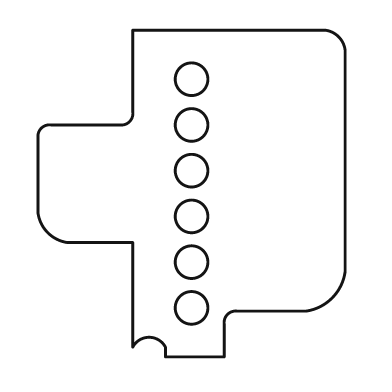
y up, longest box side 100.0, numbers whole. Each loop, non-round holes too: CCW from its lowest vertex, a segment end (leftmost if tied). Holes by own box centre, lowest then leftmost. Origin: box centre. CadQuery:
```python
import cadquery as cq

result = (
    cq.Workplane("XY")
    .moveTo(-8.0, -50.0)
    .lineTo(10.0, -50.0)
    .lineTo(10.0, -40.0)
    .threePointArc((11.0, -37.0), (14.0, -36.0))
    .lineTo(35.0, -36.0)
    .threePointArc((43.0, -32.0), (47.0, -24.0))
    .lineTo(47.0, 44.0)
    .threePointArc((45.0, 48.0), (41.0, 50.0))
    .lineTo(-18.0, 50.0)
    .lineTo(-18.0, 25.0)
    .threePointArc((-19.0, 22.0), (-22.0, 21.0))
    .lineTo(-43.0, 21.0)
    .threePointArc((-46.0, 20.0), (-47.0, 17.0))
    .lineTo(-47.0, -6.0)
    .threePointArc((-44.0, -12.0), (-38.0, -15.0))
    .lineTo(-18.0, -15.0)
    .lineTo(-18.0, -47.0)
    .threePointArc((-13.0, -44.0), (-8.0, -47.0))
    .close()
    .moveTo(0.0, -35.0)
    .circle(5.0)
    .moveTo(0.0, -21.0)
    .circle(5.0)
    .moveTo(0.0, -7.0)
    .circle(5.0)
    .moveTo(0.0, 7.0)
    .circle(5.0)
    .moveTo(0.0, 21.0)
    .circle(5.0)
    .moveTo(0.0, 35.0)
    .circle(5.0)
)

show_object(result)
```